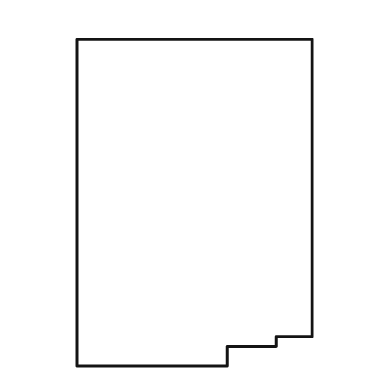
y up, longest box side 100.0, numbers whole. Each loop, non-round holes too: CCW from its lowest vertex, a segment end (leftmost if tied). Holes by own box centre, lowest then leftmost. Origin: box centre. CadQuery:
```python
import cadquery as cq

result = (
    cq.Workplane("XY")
    .moveTo(-36.0, -50.0)
    .lineTo(10.0, -50.0)
    .lineTo(10.0, -44.0)
    .lineTo(25.0, -44.0)
    .lineTo(25.0, -41.0)
    .lineTo(36.0, -41.0)
    .lineTo(36.0, 50.0)
    .lineTo(-36.0, 50.0)
    .close()
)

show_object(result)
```